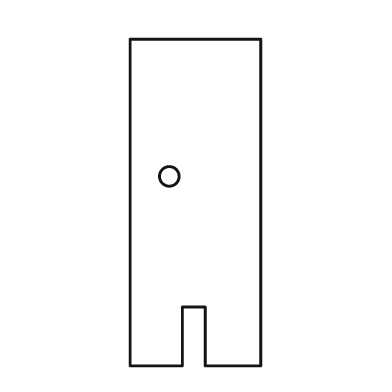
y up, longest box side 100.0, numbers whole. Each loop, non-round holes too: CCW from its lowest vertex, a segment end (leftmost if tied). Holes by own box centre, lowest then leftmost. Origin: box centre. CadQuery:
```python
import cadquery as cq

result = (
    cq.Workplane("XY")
    .moveTo(-20.0, -50.0)
    .lineTo(-4.0, -50.0)
    .lineTo(-4.0, -32.0)
    .lineTo(3.0, -32.0)
    .lineTo(3.0, -50.0)
    .lineTo(20.0, -50.0)
    .lineTo(20.0, 50.0)
    .lineTo(-20.0, 50.0)
    .close()
    .moveTo(-8.0, 8.0)
    .circle(3.0)
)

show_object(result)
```